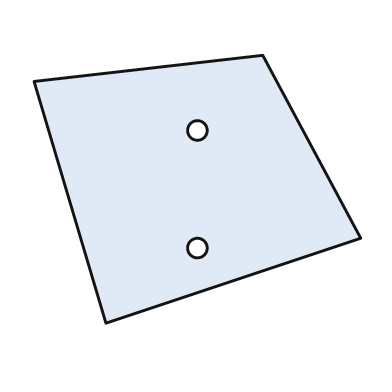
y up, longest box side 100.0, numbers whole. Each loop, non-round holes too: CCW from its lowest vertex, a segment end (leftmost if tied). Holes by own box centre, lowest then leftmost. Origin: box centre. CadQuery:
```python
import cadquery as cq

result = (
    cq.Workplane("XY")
    .moveTo(-28.0, -41.0)
    .lineTo(50.0, -15.0)
    .lineTo(20.0, 41.0)
    .lineTo(-50.0, 33.0)
    .close()
    .moveTo(0.0, -18.0)
    .circle(3.0)
    .moveTo(0.0, 18.0)
    .circle(3.0)
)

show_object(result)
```